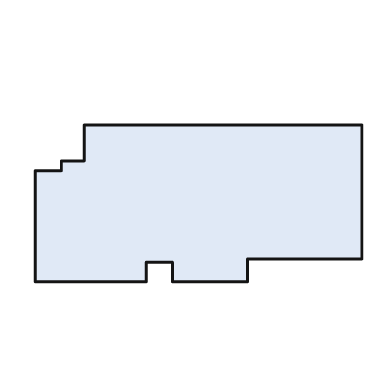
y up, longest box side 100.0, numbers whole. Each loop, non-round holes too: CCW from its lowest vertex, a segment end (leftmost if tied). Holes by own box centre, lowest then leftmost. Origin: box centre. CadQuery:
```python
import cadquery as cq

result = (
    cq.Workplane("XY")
    .moveTo(-50.0, -24.0)
    .lineTo(-16.0, -24.0)
    .lineTo(-16.0, -18.0)
    .lineTo(-8.0, -18.0)
    .lineTo(-8.0, -24.0)
    .lineTo(15.0, -24.0)
    .lineTo(15.0, -17.0)
    .lineTo(50.0, -17.0)
    .lineTo(50.0, 24.0)
    .lineTo(-35.0, 24.0)
    .lineTo(-35.0, 13.0)
    .lineTo(-42.0, 13.0)
    .lineTo(-42.0, 10.0)
    .lineTo(-50.0, 10.0)
    .close()
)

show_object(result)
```